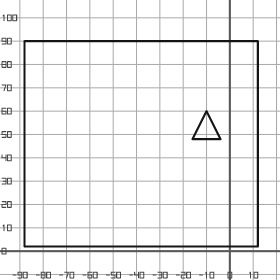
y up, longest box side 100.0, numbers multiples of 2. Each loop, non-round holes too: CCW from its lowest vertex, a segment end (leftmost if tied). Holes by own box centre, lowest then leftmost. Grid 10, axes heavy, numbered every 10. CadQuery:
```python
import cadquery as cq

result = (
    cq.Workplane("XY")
    .moveTo(-88.0, 2.0)
    .lineTo(12.0, 2.0)
    .lineTo(12.0, 90.0)
    .lineTo(-88.0, 90.0)
    .close()
    .moveTo(-16.0, 48.0)
    .lineTo(-4.0, 48.0)
    .lineTo(-10.0, 60.0)
    .close()
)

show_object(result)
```